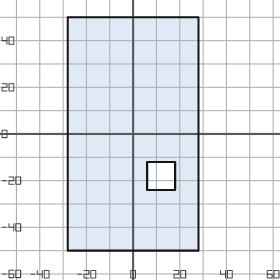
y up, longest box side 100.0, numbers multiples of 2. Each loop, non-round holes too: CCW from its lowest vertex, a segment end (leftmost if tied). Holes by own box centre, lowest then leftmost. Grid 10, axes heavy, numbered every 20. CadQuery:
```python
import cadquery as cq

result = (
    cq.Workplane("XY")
    .moveTo(-28.0, -50.0)
    .lineTo(28.0, -50.0)
    .lineTo(28.0, 50.0)
    .lineTo(-28.0, 50.0)
    .close()
    .moveTo(6.0, -24.0)
    .lineTo(18.0, -24.0)
    .lineTo(18.0, -12.0)
    .lineTo(6.0, -12.0)
    .close()
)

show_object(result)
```